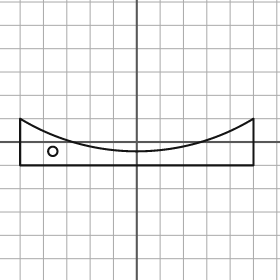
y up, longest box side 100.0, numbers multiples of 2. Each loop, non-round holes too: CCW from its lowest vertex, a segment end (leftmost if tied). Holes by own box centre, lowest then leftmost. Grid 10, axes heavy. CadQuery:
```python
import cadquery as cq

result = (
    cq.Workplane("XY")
    .moveTo(-50.0, -10.0)
    .lineTo(50.0, -10.0)
    .lineTo(50.0, 10.0)
    .threePointArc((0.0, -4.0), (-50.0, 10.0))
    .close()
    .moveTo(-36.0, -4.0)
    .circle(2.0)
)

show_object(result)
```